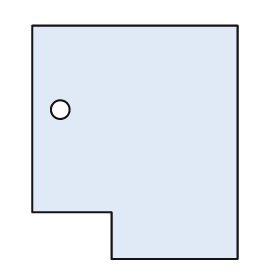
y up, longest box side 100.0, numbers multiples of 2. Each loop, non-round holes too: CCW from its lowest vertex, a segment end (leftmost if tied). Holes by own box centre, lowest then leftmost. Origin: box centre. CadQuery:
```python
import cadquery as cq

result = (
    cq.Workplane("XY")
    .moveTo(-10.0, -50.0)
    .lineTo(44.0, -50.0)
    .lineTo(44.0, 50.0)
    .lineTo(-44.0, 50.0)
    .lineTo(-44.0, -30.0)
    .lineTo(-10.0, -30.0)
    .close()
    .moveTo(-32.0, 14.0)
    .circle(4.0)
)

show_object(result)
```